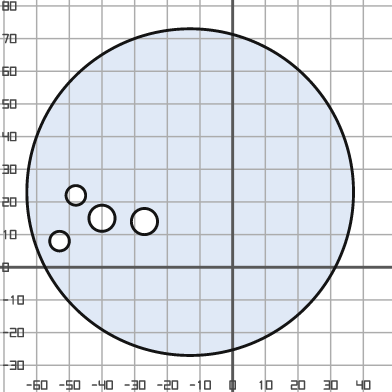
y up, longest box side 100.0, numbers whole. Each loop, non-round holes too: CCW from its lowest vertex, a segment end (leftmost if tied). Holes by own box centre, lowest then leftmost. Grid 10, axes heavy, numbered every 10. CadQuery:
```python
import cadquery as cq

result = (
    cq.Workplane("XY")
    .moveTo(-13.0, 23.0)
    .circle(50.0)
    .moveTo(-53.0, 8.0)
    .circle(3.0)
    .moveTo(-27.0, 14.0)
    .circle(4.0)
    .moveTo(-40.0, 15.0)
    .circle(4.0)
    .moveTo(-48.0, 22.0)
    .circle(3.0)
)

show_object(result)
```